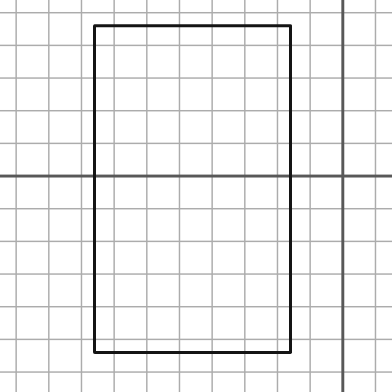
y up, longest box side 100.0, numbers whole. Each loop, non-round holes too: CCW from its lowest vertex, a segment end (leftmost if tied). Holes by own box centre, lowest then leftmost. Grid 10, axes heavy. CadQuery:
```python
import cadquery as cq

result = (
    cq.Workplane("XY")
    .moveTo(-76.0, -54.0)
    .lineTo(-16.0, -54.0)
    .lineTo(-16.0, 46.0)
    .lineTo(-76.0, 46.0)
    .close()
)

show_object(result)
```